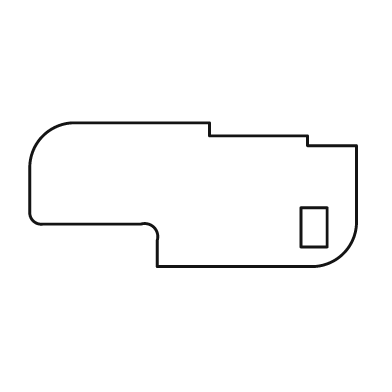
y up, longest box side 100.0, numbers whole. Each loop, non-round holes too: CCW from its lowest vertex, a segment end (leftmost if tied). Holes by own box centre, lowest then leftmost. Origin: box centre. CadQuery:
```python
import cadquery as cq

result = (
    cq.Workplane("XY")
    .moveTo(-11.0, -22.0)
    .lineTo(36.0, -22.0)
    .threePointArc((46.0, -18.0), (50.0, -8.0))
    .lineTo(50.0, 15.0)
    .lineTo(35.0, 15.0)
    .lineTo(35.0, 18.0)
    .lineTo(5.0, 18.0)
    .lineTo(5.0, 22.0)
    .lineTo(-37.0, 22.0)
    .threePointArc((-46.0, 18.0), (-50.0, 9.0))
    .lineTo(-50.0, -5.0)
    .threePointArc((-49.0, -8.0), (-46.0, -9.0))
    .lineTo(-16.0, -9.0)
    .threePointArc((-12.0, -10.0), (-11.0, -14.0))
    .close()
    .moveTo(33.0, -16.0)
    .lineTo(41.0, -16.0)
    .lineTo(41.0, -4.0)
    .lineTo(33.0, -4.0)
    .close()
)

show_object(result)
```